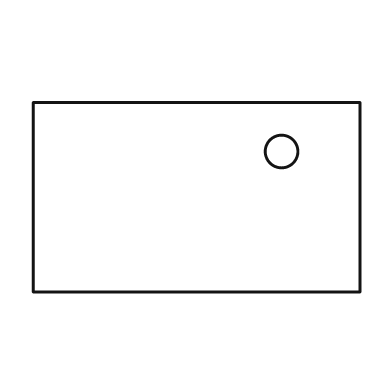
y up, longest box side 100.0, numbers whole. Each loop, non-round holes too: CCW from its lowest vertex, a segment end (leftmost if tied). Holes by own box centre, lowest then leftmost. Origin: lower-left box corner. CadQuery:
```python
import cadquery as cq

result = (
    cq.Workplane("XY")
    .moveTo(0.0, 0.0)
    .lineTo(100.0, 0.0)
    .lineTo(100.0, 58.0)
    .lineTo(0.0, 58.0)
    .close()
    .moveTo(76.0, 43.0)
    .circle(5.0)
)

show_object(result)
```